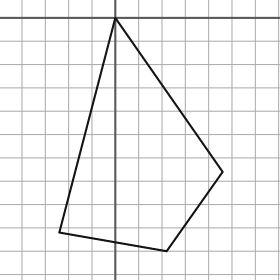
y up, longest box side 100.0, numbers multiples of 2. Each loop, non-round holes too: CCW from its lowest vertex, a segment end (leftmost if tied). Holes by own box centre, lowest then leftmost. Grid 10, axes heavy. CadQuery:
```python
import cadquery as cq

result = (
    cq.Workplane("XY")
    .moveTo(22.0, -100.0)
    .lineTo(46.0, -66.0)
    .lineTo(0.0, 0.0)
    .lineTo(-24.0, -92.0)
    .close()
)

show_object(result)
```